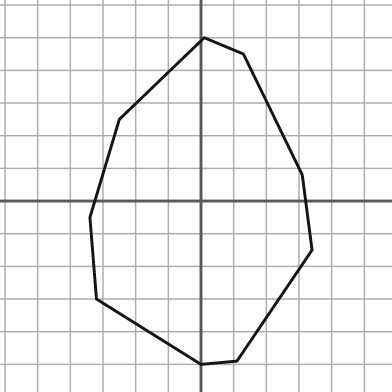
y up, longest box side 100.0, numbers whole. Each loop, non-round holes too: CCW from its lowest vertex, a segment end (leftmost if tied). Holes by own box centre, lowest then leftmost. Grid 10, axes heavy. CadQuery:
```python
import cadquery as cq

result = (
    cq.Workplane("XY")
    .moveTo(0.0, -50.0)
    .lineTo(11.0, -49.0)
    .lineTo(34.0, -15.0)
    .lineTo(31.0, 8.0)
    .lineTo(13.0, 45.0)
    .lineTo(1.0, 50.0)
    .lineTo(-25.0, 25.0)
    .lineTo(-34.0, -5.0)
    .lineTo(-32.0, -30.0)
    .close()
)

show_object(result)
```